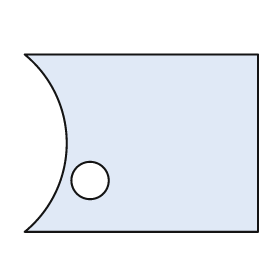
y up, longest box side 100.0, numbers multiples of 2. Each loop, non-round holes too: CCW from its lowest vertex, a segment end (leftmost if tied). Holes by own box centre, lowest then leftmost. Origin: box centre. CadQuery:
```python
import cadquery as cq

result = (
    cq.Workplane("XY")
    .moveTo(-50.0, -38.0)
    .lineTo(50.0, -38.0)
    .lineTo(50.0, 38.0)
    .lineTo(-50.0, 38.0)
    .threePointArc((-32.0, 0.0), (-50.0, -38.0))
    .close()
    .moveTo(-22.0, -16.0)
    .circle(8.0)
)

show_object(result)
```